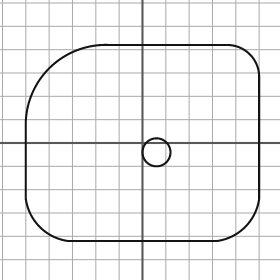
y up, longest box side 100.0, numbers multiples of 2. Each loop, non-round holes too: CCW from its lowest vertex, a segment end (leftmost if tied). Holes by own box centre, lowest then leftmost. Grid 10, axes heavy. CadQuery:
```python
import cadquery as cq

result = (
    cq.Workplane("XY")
    .moveTo(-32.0, -42.0)
    .lineTo(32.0, -42.0)
    .threePointArc((44.0, -36.0), (50.0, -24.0))
    .lineTo(50.0, 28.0)
    .threePointArc((46.0, 38.0), (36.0, 42.0))
    .lineTo(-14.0, 42.0)
    .threePointArc((-40.0, 32.0), (-50.0, 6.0))
    .lineTo(-50.0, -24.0)
    .threePointArc((-44.0, -36.0), (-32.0, -42.0))
    .close()
    .moveTo(6.0, -4.0)
    .circle(6.0)
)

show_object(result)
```